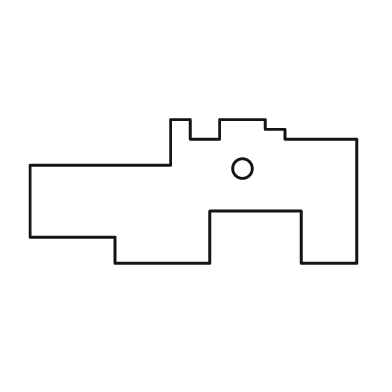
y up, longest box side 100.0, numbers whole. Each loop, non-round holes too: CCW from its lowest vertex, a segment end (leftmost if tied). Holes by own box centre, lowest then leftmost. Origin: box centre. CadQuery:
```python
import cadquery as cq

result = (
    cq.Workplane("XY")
    .moveTo(-24.0, -22.0)
    .lineTo(5.0, -22.0)
    .lineTo(5.0, -6.0)
    .lineTo(33.0, -6.0)
    .lineTo(33.0, -22.0)
    .lineTo(50.0, -22.0)
    .lineTo(50.0, 16.0)
    .lineTo(28.0, 16.0)
    .lineTo(28.0, 19.0)
    .lineTo(22.0, 19.0)
    .lineTo(22.0, 22.0)
    .lineTo(8.0, 22.0)
    .lineTo(8.0, 16.0)
    .lineTo(-1.0, 16.0)
    .lineTo(-1.0, 22.0)
    .lineTo(-7.0, 22.0)
    .lineTo(-7.0, 8.0)
    .lineTo(-50.0, 8.0)
    .lineTo(-50.0, -14.0)
    .lineTo(-24.0, -14.0)
    .close()
    .moveTo(15.0, 7.0)
    .circle(3.0)
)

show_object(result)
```